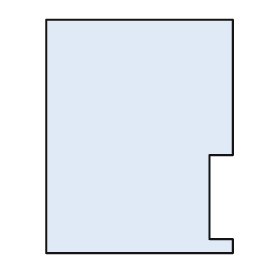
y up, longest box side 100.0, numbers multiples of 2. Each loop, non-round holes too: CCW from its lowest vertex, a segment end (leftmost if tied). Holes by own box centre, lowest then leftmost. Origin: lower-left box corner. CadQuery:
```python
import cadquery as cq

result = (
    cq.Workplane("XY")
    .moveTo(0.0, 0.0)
    .lineTo(80.0, 0.0)
    .lineTo(80.0, 6.0)
    .lineTo(70.0, 6.0)
    .lineTo(70.0, 42.0)
    .lineTo(80.0, 42.0)
    .lineTo(80.0, 100.0)
    .lineTo(0.0, 100.0)
    .close()
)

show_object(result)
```